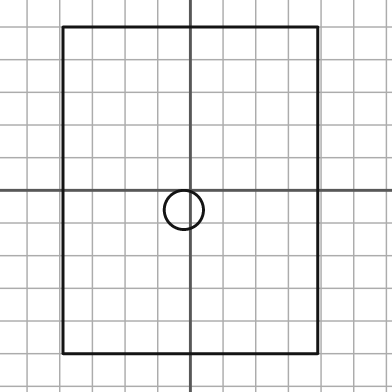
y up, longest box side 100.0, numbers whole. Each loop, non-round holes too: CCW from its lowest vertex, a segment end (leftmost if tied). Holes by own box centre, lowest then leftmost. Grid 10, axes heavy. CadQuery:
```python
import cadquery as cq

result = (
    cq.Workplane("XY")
    .moveTo(-39.0, -50.0)
    .lineTo(39.0, -50.0)
    .lineTo(39.0, 50.0)
    .lineTo(-39.0, 50.0)
    .close()
    .moveTo(-2.0, -6.0)
    .circle(6.0)
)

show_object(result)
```